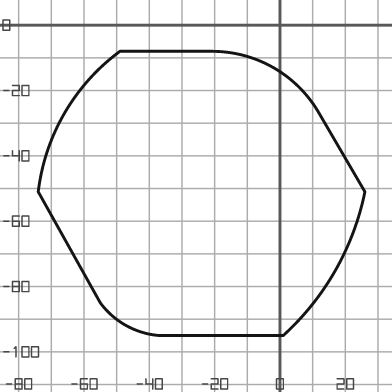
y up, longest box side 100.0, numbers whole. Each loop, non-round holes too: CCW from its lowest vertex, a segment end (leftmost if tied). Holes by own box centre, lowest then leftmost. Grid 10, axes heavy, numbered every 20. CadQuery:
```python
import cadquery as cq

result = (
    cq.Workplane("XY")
    .moveTo(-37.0, -95.0)
    .lineTo(1.0, -95.0)
    .threePointArc((17.0, -75.0), (26.0, -51.0))
    .lineTo(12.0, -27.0)
    .threePointArc((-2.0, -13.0), (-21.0, -8.0))
    .lineTo(-49.0, -8.0)
    .threePointArc((-66.0, -27.0), (-74.0, -51.0))
    .lineTo(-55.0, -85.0)
    .threePointArc((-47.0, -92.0), (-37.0, -95.0))
    .close()
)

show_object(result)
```